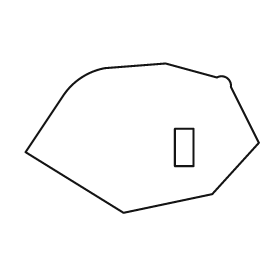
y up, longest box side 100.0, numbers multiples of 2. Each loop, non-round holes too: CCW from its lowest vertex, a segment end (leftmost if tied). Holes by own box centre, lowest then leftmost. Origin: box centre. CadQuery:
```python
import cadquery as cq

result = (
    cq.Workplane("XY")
    .moveTo(-8.0, -32.0)
    .lineTo(30.0, -24.0)
    .lineTo(50.0, -2.0)
    .lineTo(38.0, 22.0)
    .threePointArc((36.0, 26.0), (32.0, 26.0))
    .lineTo(10.0, 32.0)
    .lineTo(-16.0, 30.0)
    .threePointArc((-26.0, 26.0), (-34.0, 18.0))
    .lineTo(-50.0, -6.0)
    .close()
    .moveTo(14.0, -12.0)
    .lineTo(22.0, -12.0)
    .lineTo(22.0, 4.0)
    .lineTo(14.0, 4.0)
    .close()
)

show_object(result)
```